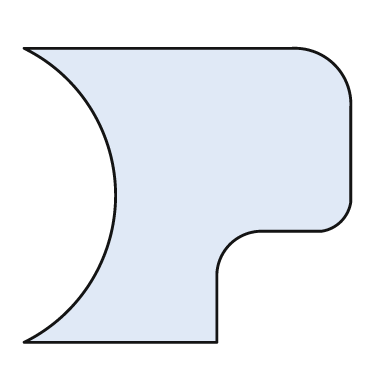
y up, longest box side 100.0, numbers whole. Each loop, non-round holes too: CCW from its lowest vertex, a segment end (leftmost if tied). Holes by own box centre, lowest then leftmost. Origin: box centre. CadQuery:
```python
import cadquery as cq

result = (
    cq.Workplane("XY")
    .moveTo(-50.0, -45.0)
    .lineTo(9.0, -45.0)
    .lineTo(9.0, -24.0)
    .threePointArc((13.0, -15.0), (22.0, -11.0))
    .lineTo(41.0, -11.0)
    .threePointArc((47.0, -8.0), (50.0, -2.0))
    .lineTo(50.0, 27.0)
    .threePointArc((45.0, 40.0), (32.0, 45.0))
    .lineTo(-50.0, 45.0)
    .threePointArc((-22.0, 0.0), (-50.0, -45.0))
    .close()
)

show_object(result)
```